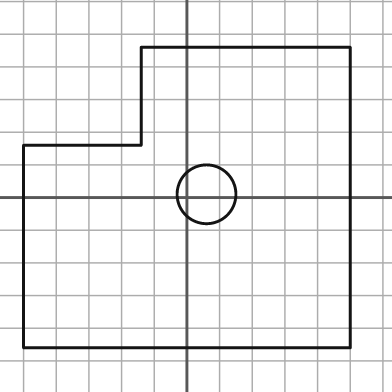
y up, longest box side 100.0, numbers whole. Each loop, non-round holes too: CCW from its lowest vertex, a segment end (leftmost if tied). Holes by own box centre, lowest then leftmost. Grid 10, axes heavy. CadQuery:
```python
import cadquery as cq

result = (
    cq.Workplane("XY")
    .moveTo(-50.0, -46.0)
    .lineTo(50.0, -46.0)
    .lineTo(50.0, 46.0)
    .lineTo(-14.0, 46.0)
    .lineTo(-14.0, 16.0)
    .lineTo(-50.0, 16.0)
    .close()
    .moveTo(6.0, 1.0)
    .circle(9.0)
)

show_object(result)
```